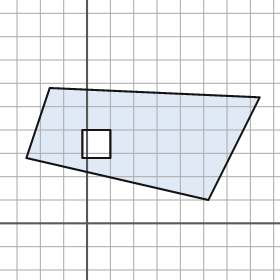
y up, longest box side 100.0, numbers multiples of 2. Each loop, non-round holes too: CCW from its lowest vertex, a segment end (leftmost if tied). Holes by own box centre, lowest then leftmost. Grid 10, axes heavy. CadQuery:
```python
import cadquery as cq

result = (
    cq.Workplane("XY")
    .moveTo(52.0, 10.0)
    .lineTo(74.0, 54.0)
    .lineTo(-16.0, 58.0)
    .lineTo(-26.0, 28.0)
    .close()
    .moveTo(-2.0, 28.0)
    .lineTo(10.0, 28.0)
    .lineTo(10.0, 40.0)
    .lineTo(-2.0, 40.0)
    .close()
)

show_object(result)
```